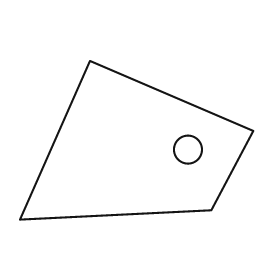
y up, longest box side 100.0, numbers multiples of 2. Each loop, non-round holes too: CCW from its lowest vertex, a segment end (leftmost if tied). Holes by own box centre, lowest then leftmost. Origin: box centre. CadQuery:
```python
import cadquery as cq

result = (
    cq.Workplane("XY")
    .moveTo(-50.0, -34.0)
    .lineTo(32.0, -30.0)
    .lineTo(50.0, 4.0)
    .lineTo(-20.0, 34.0)
    .close()
    .moveTo(22.0, -4.0)
    .circle(6.0)
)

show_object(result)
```